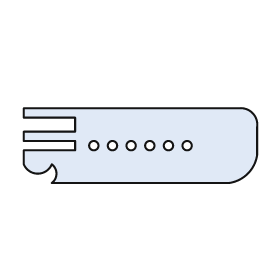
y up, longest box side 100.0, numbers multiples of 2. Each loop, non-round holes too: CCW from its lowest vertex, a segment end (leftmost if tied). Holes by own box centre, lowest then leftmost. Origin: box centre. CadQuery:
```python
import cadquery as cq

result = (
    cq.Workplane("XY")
    .moveTo(-38.0, -16.0)
    .lineTo(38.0, -16.0)
    .threePointArc((46.0, -12.0), (50.0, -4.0))
    .lineTo(50.0, 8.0)
    .threePointArc((48.0, 14.0), (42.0, 16.0))
    .lineTo(-50.0, 16.0)
    .lineTo(-50.0, 12.0)
    .lineTo(-28.0, 12.0)
    .lineTo(-28.0, 6.0)
    .lineTo(-50.0, 6.0)
    .lineTo(-50.0, 2.0)
    .lineTo(-28.0, 2.0)
    .lineTo(-28.0, -2.0)
    .lineTo(-50.0, -2.0)
    .lineTo(-50.0, -8.0)
    .threePointArc((-44.0, -12.0), (-38.0, -8.0))
    .threePointArc((-36.0, -12.0), (-38.0, -16.0))
    .close()
    .moveTo(-20.0, 0.0)
    .circle(2.0)
    .moveTo(-12.0, 0.0)
    .circle(2.0)
    .moveTo(-4.0, 0.0)
    .circle(2.0)
    .moveTo(4.0, 0.0)
    .circle(2.0)
    .moveTo(12.0, 0.0)
    .circle(2.0)
    .moveTo(20.0, 0.0)
    .circle(2.0)
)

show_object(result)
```